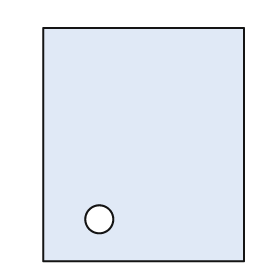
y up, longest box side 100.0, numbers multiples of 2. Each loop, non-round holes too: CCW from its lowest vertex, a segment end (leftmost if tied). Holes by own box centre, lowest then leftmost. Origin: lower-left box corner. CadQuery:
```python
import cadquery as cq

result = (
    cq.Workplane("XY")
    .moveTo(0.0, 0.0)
    .lineTo(86.0, 0.0)
    .lineTo(86.0, 100.0)
    .lineTo(0.0, 100.0)
    .close()
    .moveTo(24.0, 18.0)
    .circle(6.0)
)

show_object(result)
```